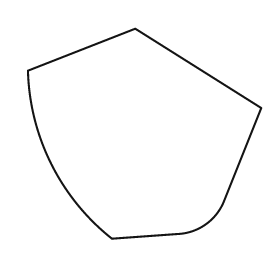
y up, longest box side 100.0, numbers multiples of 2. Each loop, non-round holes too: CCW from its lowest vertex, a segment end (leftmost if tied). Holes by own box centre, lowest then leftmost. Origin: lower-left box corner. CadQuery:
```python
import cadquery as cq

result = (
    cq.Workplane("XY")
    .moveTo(36.0, 0.0)
    .lineTo(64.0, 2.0)
    .threePointArc((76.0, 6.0), (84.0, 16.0))
    .lineTo(100.0, 56.0)
    .lineTo(46.0, 90.0)
    .lineTo(0.0, 72.0)
    .threePointArc((10.0, 32.0), (36.0, 0.0))
    .close()
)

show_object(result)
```